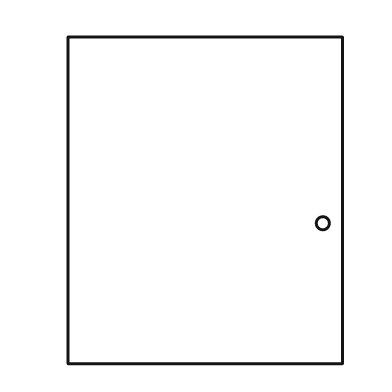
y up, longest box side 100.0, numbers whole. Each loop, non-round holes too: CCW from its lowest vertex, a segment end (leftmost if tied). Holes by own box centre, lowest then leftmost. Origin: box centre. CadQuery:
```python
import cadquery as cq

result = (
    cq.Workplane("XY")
    .moveTo(-42.0, -50.0)
    .lineTo(42.0, -50.0)
    .lineTo(42.0, 50.0)
    .lineTo(-42.0, 50.0)
    .close()
    .moveTo(36.0, -7.0)
    .circle(2.0)
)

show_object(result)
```